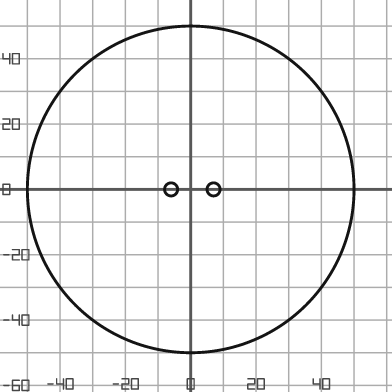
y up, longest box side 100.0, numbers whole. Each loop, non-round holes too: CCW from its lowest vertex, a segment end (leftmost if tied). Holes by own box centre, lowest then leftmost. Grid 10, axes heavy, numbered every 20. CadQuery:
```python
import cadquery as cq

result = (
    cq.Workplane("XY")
    .moveTo(0.0, 0.0)
    .circle(50.0)
    .moveTo(-6.0, 0.0)
    .circle(2.0)
    .moveTo(7.0, 0.0)
    .circle(2.0)
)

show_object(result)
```